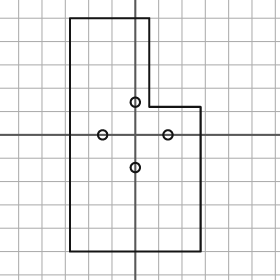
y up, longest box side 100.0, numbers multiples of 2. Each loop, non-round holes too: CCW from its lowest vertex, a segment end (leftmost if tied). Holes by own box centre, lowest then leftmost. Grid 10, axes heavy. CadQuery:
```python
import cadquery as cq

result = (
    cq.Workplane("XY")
    .moveTo(-28.0, -50.0)
    .lineTo(28.0, -50.0)
    .lineTo(28.0, 12.0)
    .lineTo(6.0, 12.0)
    .lineTo(6.0, 50.0)
    .lineTo(-28.0, 50.0)
    .close()
    .moveTo(0.0, -14.0)
    .circle(2.0)
    .moveTo(-14.0, 0.0)
    .circle(2.0)
    .moveTo(14.0, 0.0)
    .circle(2.0)
    .moveTo(0.0, 14.0)
    .circle(2.0)
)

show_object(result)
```